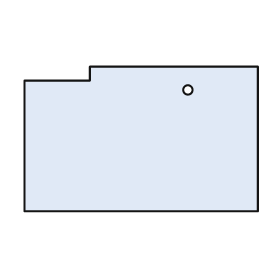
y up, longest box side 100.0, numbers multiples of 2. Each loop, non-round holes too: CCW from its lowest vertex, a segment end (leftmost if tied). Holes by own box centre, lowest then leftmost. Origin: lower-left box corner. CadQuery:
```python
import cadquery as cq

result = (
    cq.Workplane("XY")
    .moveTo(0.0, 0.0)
    .lineTo(100.0, 0.0)
    .lineTo(100.0, 62.0)
    .lineTo(28.0, 62.0)
    .lineTo(28.0, 56.0)
    .lineTo(0.0, 56.0)
    .close()
    .moveTo(70.0, 52.0)
    .circle(2.0)
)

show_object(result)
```